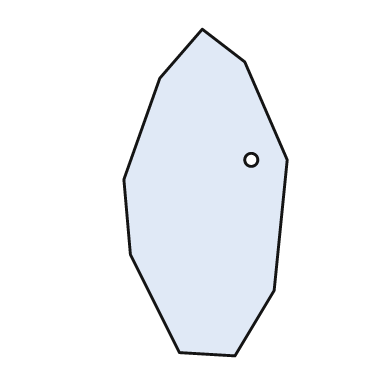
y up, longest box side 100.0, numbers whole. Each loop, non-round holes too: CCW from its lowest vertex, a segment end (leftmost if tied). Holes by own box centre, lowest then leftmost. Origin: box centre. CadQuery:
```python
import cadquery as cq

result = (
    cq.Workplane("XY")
    .moveTo(9.0, -50.0)
    .lineTo(21.0, -30.0)
    .lineTo(25.0, 10.0)
    .lineTo(12.0, 40.0)
    .lineTo(-1.0, 50.0)
    .lineTo(-14.0, 35.0)
    .lineTo(-25.0, 4.0)
    .lineTo(-23.0, -19.0)
    .lineTo(-8.0, -49.0)
    .close()
    .moveTo(14.0, 10.0)
    .circle(2.0)
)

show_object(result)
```